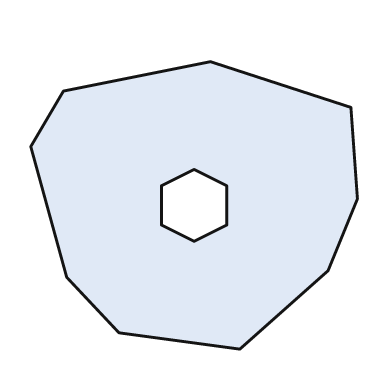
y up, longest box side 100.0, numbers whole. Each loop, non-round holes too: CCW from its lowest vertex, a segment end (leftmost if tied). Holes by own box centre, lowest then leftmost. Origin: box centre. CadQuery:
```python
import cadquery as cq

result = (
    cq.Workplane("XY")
    .moveTo(14.0, -44.0)
    .lineTo(41.0, -20.0)
    .lineTo(50.0, 2.0)
    .lineTo(48.0, 30.0)
    .lineTo(5.0, 44.0)
    .lineTo(-40.0, 35.0)
    .lineTo(-50.0, 18.0)
    .lineTo(-39.0, -22.0)
    .lineTo(-23.0, -39.0)
    .close()
    .moveTo(0.0, -11.0)
    .lineTo(10.0, -6.0)
    .lineTo(10.0, 6.0)
    .lineTo(0.0, 11.0)
    .lineTo(-10.0, 6.0)
    .lineTo(-10.0, -6.0)
    .close()
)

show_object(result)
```